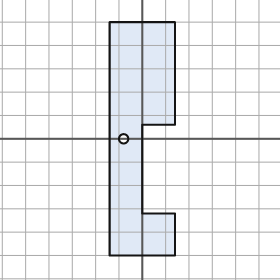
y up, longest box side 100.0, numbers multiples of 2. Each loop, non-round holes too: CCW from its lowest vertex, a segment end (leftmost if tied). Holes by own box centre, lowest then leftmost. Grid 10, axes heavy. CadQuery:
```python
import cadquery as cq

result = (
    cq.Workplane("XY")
    .moveTo(-14.0, -50.0)
    .lineTo(14.0, -50.0)
    .lineTo(14.0, -32.0)
    .lineTo(0.0, -32.0)
    .lineTo(0.0, 6.0)
    .lineTo(14.0, 6.0)
    .lineTo(14.0, 50.0)
    .lineTo(-14.0, 50.0)
    .close()
    .moveTo(-8.0, 0.0)
    .circle(2.0)
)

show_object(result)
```